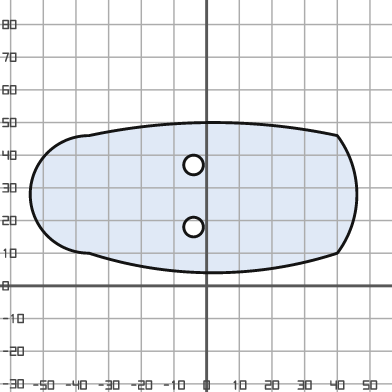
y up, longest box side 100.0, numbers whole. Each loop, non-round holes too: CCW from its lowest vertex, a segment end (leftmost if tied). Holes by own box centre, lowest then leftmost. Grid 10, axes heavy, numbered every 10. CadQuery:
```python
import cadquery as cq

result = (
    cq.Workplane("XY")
    .moveTo(-36.0, 10.0)
    .threePointArc((2.0, 4.0), (40.0, 10.0))
    .threePointArc((46.0, 28.0), (40.0, 46.0))
    .threePointArc((2.0, 50.0), (-36.0, 46.0))
    .threePointArc((-54.0, 28.0), (-36.0, 10.0))
    .close()
    .moveTo(-4.0, 18.0)
    .circle(3.0)
    .moveTo(-4.0, 37.0)
    .circle(3.0)
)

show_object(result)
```